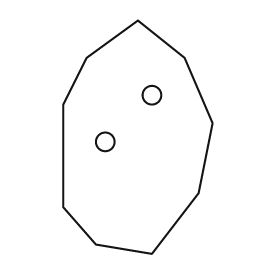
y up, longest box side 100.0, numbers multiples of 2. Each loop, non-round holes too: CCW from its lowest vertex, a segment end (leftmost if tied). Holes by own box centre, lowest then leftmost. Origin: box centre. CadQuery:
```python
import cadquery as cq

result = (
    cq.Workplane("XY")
    .moveTo(6.0, -50.0)
    .lineTo(26.0, -24.0)
    .lineTo(32.0, 6.0)
    .lineTo(20.0, 34.0)
    .lineTo(0.0, 50.0)
    .lineTo(-22.0, 34.0)
    .lineTo(-32.0, 14.0)
    .lineTo(-32.0, -30.0)
    .lineTo(-18.0, -46.0)
    .close()
    .moveTo(-14.0, -2.0)
    .circle(4.0)
    .moveTo(6.0, 18.0)
    .circle(4.0)
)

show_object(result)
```